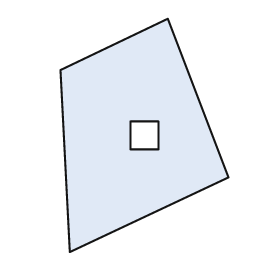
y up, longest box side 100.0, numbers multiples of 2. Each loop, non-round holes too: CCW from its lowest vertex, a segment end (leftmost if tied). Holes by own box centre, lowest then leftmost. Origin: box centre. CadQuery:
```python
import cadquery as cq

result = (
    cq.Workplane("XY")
    .moveTo(-32.0, -50.0)
    .lineTo(36.0, -18.0)
    .lineTo(10.0, 50.0)
    .lineTo(-36.0, 28.0)
    .close()
    .moveTo(-6.0, -6.0)
    .lineTo(6.0, -6.0)
    .lineTo(6.0, 6.0)
    .lineTo(-6.0, 6.0)
    .close()
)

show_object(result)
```